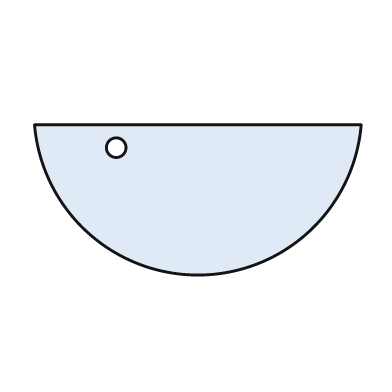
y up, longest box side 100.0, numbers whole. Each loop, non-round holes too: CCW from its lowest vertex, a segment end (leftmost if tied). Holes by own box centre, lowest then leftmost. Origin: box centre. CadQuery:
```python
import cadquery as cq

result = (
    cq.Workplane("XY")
    .moveTo(-50.0, 23.0)
    .threePointArc((0.0, -23.0), (50.0, 23.0))
    .close()
    .moveTo(-25.0, 16.0)
    .circle(3.0)
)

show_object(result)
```